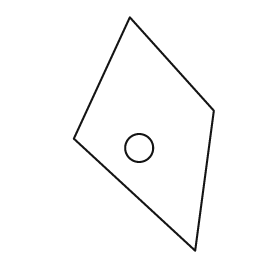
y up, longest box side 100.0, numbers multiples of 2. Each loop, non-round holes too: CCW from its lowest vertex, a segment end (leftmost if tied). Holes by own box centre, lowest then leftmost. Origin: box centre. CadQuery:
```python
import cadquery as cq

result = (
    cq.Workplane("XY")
    .moveTo(22.0, -50.0)
    .lineTo(30.0, 10.0)
    .lineTo(-6.0, 50.0)
    .lineTo(-30.0, -2.0)
    .close()
    .moveTo(-2.0, -6.0)
    .circle(6.0)
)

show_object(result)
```